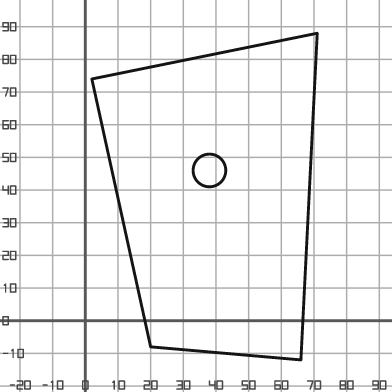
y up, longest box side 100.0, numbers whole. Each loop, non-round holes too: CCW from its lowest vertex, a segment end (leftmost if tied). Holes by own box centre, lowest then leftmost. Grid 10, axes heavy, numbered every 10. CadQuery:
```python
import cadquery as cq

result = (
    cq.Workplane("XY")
    .moveTo(66.0, -12.0)
    .lineTo(71.0, 88.0)
    .lineTo(2.0, 74.0)
    .lineTo(20.0, -8.0)
    .close()
    .moveTo(38.0, 46.0)
    .circle(5.0)
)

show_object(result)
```